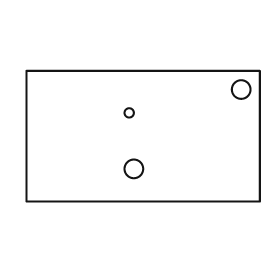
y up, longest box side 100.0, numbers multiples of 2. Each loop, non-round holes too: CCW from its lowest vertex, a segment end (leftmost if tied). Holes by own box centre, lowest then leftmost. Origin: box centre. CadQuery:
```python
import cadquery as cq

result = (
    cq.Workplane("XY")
    .moveTo(-50.0, -28.0)
    .lineTo(50.0, -28.0)
    .lineTo(50.0, 28.0)
    .lineTo(-50.0, 28.0)
    .close()
    .moveTo(-4.0, -14.0)
    .circle(4.0)
    .moveTo(-6.0, 10.0)
    .circle(2.0)
    .moveTo(42.0, 20.0)
    .circle(4.0)
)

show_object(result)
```